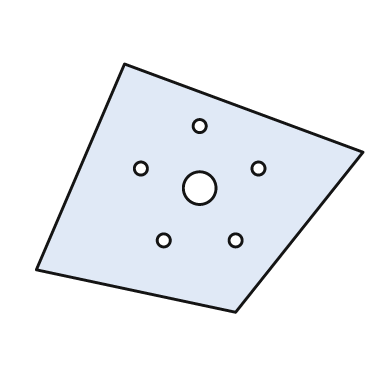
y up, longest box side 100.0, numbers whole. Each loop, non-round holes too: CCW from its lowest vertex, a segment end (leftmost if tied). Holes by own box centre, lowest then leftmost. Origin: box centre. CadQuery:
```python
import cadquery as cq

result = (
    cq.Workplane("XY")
    .moveTo(11.0, -38.0)
    .lineTo(50.0, 11.0)
    .lineTo(-23.0, 38.0)
    .lineTo(-50.0, -25.0)
    .close()
    .moveTo(-11.0, -16.0)
    .circle(2.0)
    .moveTo(11.0, -16.0)
    .circle(2.0)
    .moveTo(0.0, 0.0)
    .circle(5.0)
    .moveTo(-18.0, 6.0)
    .circle(2.0)
    .moveTo(18.0, 6.0)
    .circle(2.0)
    .moveTo(0.0, 19.0)
    .circle(2.0)
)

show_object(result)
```